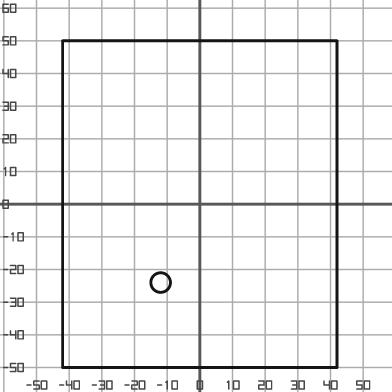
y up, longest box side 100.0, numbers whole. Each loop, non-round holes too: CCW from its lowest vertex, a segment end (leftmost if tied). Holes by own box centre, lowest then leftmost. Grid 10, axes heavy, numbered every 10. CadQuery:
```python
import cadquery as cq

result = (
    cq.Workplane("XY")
    .moveTo(-42.0, -50.0)
    .lineTo(42.0, -50.0)
    .lineTo(42.0, 50.0)
    .lineTo(-42.0, 50.0)
    .close()
    .moveTo(-12.0, -24.0)
    .circle(3.0)
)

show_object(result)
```